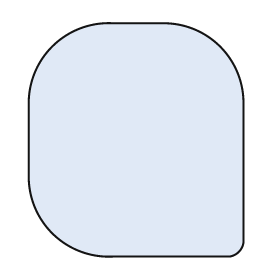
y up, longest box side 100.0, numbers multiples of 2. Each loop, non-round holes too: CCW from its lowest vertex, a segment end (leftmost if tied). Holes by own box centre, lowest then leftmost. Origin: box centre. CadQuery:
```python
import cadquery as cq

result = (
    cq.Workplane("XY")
    .moveTo(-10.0, -50.0)
    .lineTo(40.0, -50.0)
    .threePointArc((44.0, -48.0), (46.0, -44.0))
    .lineTo(46.0, 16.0)
    .threePointArc((36.0, 40.0), (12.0, 50.0))
    .lineTo(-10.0, 50.0)
    .threePointArc((-36.0, 40.0), (-46.0, 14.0))
    .lineTo(-46.0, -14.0)
    .threePointArc((-36.0, -40.0), (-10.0, -50.0))
    .close()
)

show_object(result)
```